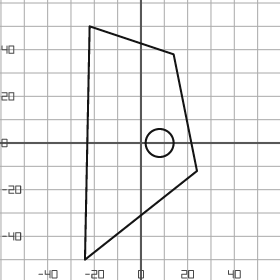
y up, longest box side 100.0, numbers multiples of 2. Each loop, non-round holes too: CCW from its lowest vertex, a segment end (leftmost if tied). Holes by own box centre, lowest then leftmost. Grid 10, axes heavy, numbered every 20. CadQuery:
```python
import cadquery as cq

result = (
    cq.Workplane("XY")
    .moveTo(-24.0, -50.0)
    .lineTo(24.0, -12.0)
    .lineTo(14.0, 38.0)
    .lineTo(-22.0, 50.0)
    .close()
    .moveTo(8.0, 0.0)
    .circle(6.0)
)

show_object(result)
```